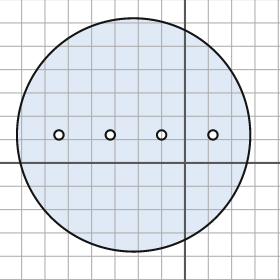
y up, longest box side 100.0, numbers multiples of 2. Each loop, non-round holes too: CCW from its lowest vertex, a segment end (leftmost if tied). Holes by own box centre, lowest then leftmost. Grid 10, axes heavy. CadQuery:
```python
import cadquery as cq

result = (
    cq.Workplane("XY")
    .moveTo(-22.0, 12.0)
    .circle(50.0)
    .moveTo(-54.0, 12.0)
    .circle(2.0)
    .moveTo(-32.0, 12.0)
    .circle(2.0)
    .moveTo(-10.0, 12.0)
    .circle(2.0)
    .moveTo(12.0, 12.0)
    .circle(2.0)
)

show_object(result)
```